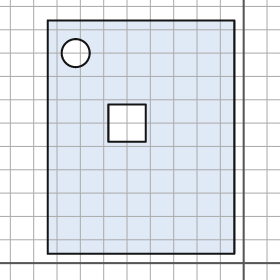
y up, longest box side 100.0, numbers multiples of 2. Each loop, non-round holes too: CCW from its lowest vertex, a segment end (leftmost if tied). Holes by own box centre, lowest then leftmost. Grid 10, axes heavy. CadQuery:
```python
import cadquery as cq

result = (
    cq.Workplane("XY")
    .moveTo(-84.0, 4.0)
    .lineTo(-4.0, 4.0)
    .lineTo(-4.0, 104.0)
    .lineTo(-84.0, 104.0)
    .close()
    .moveTo(-58.0, 52.0)
    .lineTo(-42.0, 52.0)
    .lineTo(-42.0, 68.0)
    .lineTo(-58.0, 68.0)
    .close()
    .moveTo(-72.0, 90.0)
    .circle(6.0)
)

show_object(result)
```